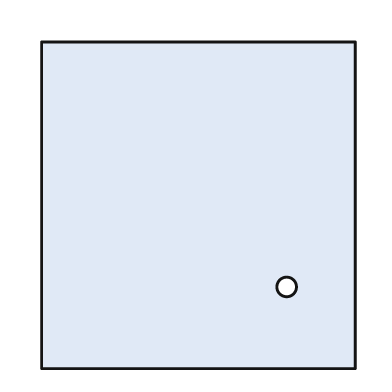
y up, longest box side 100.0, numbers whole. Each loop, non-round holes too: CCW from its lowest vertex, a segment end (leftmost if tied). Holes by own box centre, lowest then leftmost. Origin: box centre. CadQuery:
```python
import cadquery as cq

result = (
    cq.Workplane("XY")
    .moveTo(-48.0, -50.0)
    .lineTo(48.0, -50.0)
    .lineTo(48.0, 50.0)
    .lineTo(-48.0, 50.0)
    .close()
    .moveTo(27.0, -25.0)
    .circle(3.0)
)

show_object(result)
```